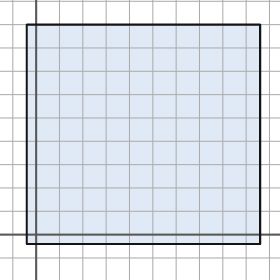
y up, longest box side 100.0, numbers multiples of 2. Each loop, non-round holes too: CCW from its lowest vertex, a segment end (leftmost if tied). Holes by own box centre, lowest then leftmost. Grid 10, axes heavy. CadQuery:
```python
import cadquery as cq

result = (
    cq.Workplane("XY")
    .moveTo(-4.0, -4.0)
    .lineTo(96.0, -4.0)
    .lineTo(96.0, 90.0)
    .lineTo(-4.0, 90.0)
    .close()
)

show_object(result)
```